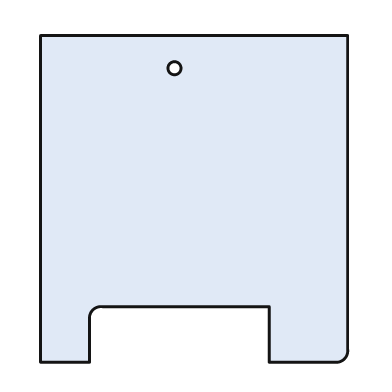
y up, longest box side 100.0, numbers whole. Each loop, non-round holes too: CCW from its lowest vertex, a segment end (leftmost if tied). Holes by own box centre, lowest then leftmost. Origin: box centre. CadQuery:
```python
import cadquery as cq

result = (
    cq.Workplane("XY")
    .moveTo(-47.0, -50.0)
    .lineTo(-32.0, -50.0)
    .lineTo(-32.0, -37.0)
    .threePointArc((-31.0, -34.0), (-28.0, -33.0))
    .lineTo(23.0, -33.0)
    .lineTo(23.0, -50.0)
    .lineTo(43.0, -50.0)
    .threePointArc((46.0, -49.0), (47.0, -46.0))
    .lineTo(47.0, 50.0)
    .lineTo(-47.0, 50.0)
    .close()
    .moveTo(-6.0, 40.0)
    .circle(2.0)
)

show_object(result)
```